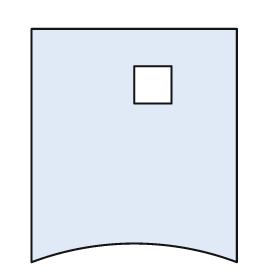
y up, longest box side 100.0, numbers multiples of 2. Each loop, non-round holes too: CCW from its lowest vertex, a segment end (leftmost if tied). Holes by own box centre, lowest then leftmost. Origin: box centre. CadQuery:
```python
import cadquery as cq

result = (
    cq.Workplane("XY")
    .moveTo(-44.0, -50.0)
    .threePointArc((0.0, -42.0), (44.0, -50.0))
    .lineTo(44.0, 50.0)
    .lineTo(-44.0, 50.0)
    .close()
    .moveTo(0.0, 18.0)
    .lineTo(16.0, 18.0)
    .lineTo(16.0, 34.0)
    .lineTo(0.0, 34.0)
    .close()
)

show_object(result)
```